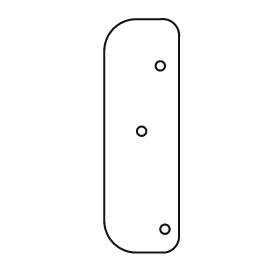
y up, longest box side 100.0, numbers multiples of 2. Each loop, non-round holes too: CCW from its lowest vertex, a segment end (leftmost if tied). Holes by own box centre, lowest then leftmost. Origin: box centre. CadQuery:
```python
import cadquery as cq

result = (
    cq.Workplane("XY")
    .moveTo(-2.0, -50.0)
    .lineTo(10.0, -50.0)
    .threePointArc((14.0, -48.0), (16.0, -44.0))
    .lineTo(16.0, 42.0)
    .threePointArc((14.0, 48.0), (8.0, 50.0))
    .lineTo(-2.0, 50.0)
    .threePointArc((-12.0, 46.0), (-16.0, 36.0))
    .lineTo(-16.0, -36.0)
    .threePointArc((-12.0, -46.0), (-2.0, -50.0))
    .close()
    .moveTo(10.0, -40.0)
    .circle(2.0)
    .moveTo(0.0, 2.0)
    .circle(2.0)
    .moveTo(8.0, 30.0)
    .circle(2.0)
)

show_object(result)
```